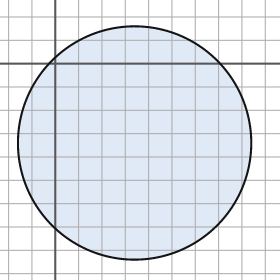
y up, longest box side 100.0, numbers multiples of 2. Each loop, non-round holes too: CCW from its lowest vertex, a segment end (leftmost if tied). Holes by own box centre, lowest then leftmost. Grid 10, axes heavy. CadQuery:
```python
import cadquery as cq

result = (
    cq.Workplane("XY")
    .moveTo(34.0, -34.0)
    .circle(50.0)
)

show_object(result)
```